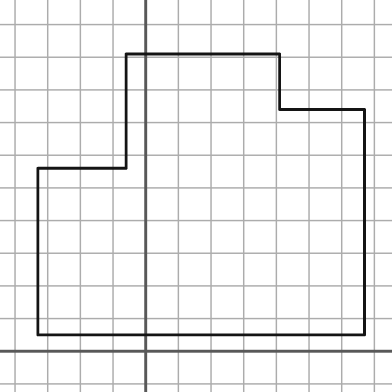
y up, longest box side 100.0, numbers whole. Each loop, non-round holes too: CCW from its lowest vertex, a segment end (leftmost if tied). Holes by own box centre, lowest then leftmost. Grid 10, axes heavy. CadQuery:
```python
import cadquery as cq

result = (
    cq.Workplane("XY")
    .moveTo(-33.0, 5.0)
    .lineTo(67.0, 5.0)
    .lineTo(67.0, 74.0)
    .lineTo(41.0, 74.0)
    .lineTo(41.0, 91.0)
    .lineTo(-6.0, 91.0)
    .lineTo(-6.0, 56.0)
    .lineTo(-33.0, 56.0)
    .close()
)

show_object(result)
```